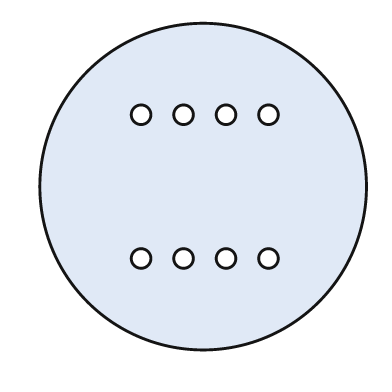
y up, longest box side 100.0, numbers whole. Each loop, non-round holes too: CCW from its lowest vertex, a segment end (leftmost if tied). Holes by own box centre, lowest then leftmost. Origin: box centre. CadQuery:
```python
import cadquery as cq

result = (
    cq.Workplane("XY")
    .moveTo(0.0, 0.0)
    .circle(50.0)
    .moveTo(-19.0, -22.0)
    .circle(3.0)
    .moveTo(-6.0, -22.0)
    .circle(3.0)
    .moveTo(7.0, -22.0)
    .circle(3.0)
    .moveTo(20.0, -22.0)
    .circle(3.0)
    .moveTo(-19.0, 22.0)
    .circle(3.0)
    .moveTo(-6.0, 22.0)
    .circle(3.0)
    .moveTo(7.0, 22.0)
    .circle(3.0)
    .moveTo(20.0, 22.0)
    .circle(3.0)
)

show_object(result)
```